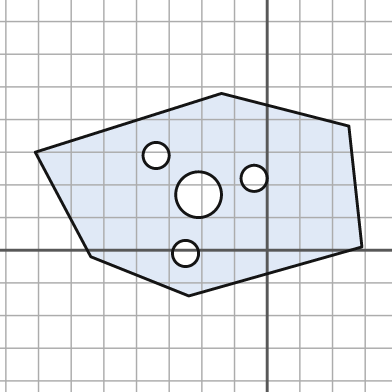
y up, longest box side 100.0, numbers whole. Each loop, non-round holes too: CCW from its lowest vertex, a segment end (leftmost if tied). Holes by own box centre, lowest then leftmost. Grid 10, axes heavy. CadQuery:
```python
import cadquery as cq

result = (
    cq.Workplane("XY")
    .moveTo(-24.0, -14.0)
    .lineTo(29.0, 1.0)
    .lineTo(25.0, 38.0)
    .lineTo(-14.0, 48.0)
    .lineTo(-71.0, 30.0)
    .lineTo(-54.0, -2.0)
    .close()
    .moveTo(-25.0, -1.0)
    .circle(4.0)
    .moveTo(-21.0, 17.0)
    .circle(7.0)
    .moveTo(-4.0, 22.0)
    .circle(4.0)
    .moveTo(-34.0, 29.0)
    .circle(4.0)
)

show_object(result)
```